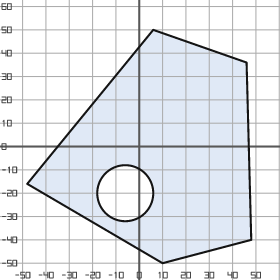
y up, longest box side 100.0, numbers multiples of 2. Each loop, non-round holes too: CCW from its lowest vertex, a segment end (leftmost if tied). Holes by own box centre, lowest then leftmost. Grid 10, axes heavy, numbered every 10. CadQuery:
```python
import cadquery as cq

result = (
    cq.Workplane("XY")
    .moveTo(10.0, -50.0)
    .lineTo(48.0, -40.0)
    .lineTo(46.0, 36.0)
    .lineTo(6.0, 50.0)
    .lineTo(-48.0, -16.0)
    .close()
    .moveTo(-6.0, -20.0)
    .circle(12.0)
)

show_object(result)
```